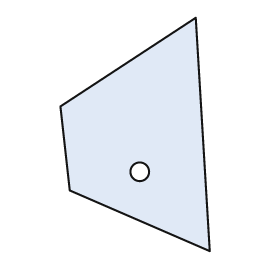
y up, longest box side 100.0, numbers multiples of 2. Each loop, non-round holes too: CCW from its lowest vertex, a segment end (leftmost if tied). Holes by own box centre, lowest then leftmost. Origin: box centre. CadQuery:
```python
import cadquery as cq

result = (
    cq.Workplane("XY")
    .moveTo(32.0, -50.0)
    .lineTo(26.0, 50.0)
    .lineTo(-32.0, 12.0)
    .lineTo(-28.0, -24.0)
    .close()
    .moveTo(2.0, -16.0)
    .circle(4.0)
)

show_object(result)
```